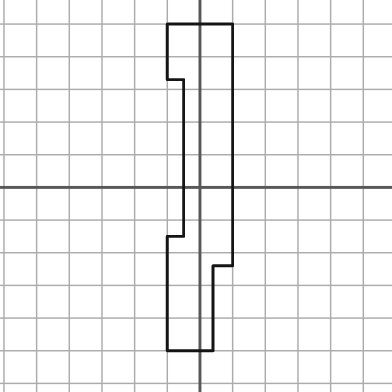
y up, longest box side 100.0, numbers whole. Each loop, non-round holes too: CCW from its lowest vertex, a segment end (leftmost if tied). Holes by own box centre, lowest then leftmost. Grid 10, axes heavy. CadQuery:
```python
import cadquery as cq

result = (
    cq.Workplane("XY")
    .moveTo(-10.0, -50.0)
    .lineTo(4.0, -50.0)
    .lineTo(4.0, -24.0)
    .lineTo(10.0, -24.0)
    .lineTo(10.0, 50.0)
    .lineTo(-10.0, 50.0)
    .lineTo(-10.0, 33.0)
    .lineTo(-5.0, 33.0)
    .lineTo(-5.0, -15.0)
    .lineTo(-10.0, -15.0)
    .close()
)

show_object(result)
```